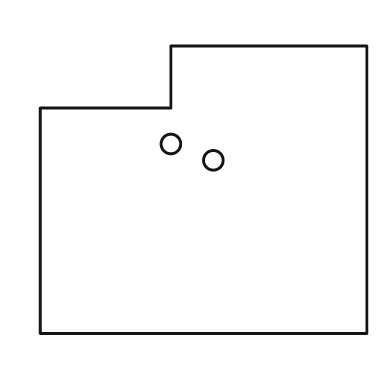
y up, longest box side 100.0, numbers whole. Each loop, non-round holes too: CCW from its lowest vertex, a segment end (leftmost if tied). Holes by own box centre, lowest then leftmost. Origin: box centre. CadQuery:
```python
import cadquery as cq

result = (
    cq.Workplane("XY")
    .moveTo(-50.0, -44.0)
    .lineTo(50.0, -44.0)
    .lineTo(50.0, 44.0)
    .lineTo(-10.0, 44.0)
    .lineTo(-10.0, 25.0)
    .lineTo(-50.0, 25.0)
    .close()
    .moveTo(3.0, 9.0)
    .circle(3.0)
    .moveTo(-10.0, 14.0)
    .circle(3.0)
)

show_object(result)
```